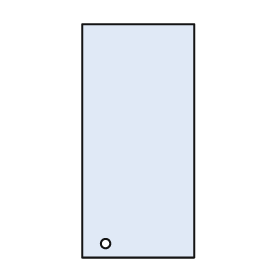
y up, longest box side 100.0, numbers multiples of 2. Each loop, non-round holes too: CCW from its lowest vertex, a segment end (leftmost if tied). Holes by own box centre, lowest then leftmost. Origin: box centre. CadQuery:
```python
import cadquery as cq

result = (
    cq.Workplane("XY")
    .moveTo(-24.0, -50.0)
    .lineTo(24.0, -50.0)
    .lineTo(24.0, 50.0)
    .lineTo(-24.0, 50.0)
    .close()
    .moveTo(-14.0, -44.0)
    .circle(2.0)
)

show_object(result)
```